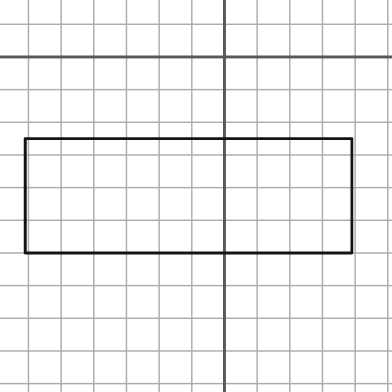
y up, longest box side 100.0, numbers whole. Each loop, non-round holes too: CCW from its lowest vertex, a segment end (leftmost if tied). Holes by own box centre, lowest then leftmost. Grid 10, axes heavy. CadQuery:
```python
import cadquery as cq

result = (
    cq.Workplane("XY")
    .moveTo(-61.0, -60.0)
    .lineTo(39.0, -60.0)
    .lineTo(39.0, -25.0)
    .lineTo(-61.0, -25.0)
    .close()
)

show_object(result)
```